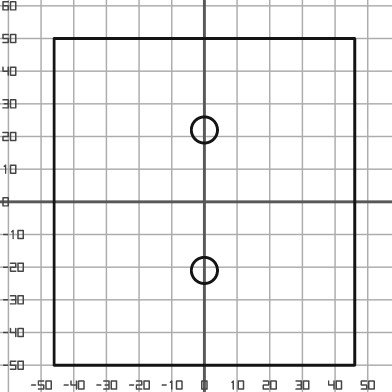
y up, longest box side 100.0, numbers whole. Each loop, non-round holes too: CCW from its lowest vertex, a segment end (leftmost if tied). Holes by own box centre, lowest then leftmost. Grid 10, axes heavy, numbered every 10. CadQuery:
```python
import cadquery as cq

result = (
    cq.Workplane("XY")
    .moveTo(-46.0, -50.0)
    .lineTo(46.0, -50.0)
    .lineTo(46.0, 50.0)
    .lineTo(-46.0, 50.0)
    .close()
    .moveTo(0.0, -21.0)
    .circle(4.0)
    .moveTo(0.0, 22.0)
    .circle(4.0)
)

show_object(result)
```